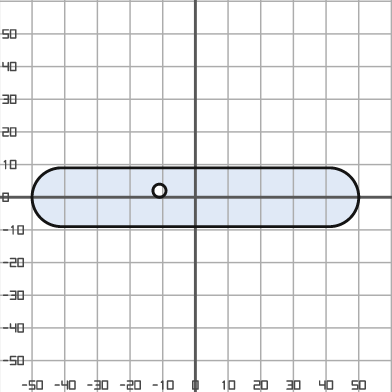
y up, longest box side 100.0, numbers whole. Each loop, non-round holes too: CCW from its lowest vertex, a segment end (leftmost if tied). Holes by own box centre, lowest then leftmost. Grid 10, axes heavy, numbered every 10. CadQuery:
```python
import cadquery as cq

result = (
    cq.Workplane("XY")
    .moveTo(-41.0, -9.0)
    .lineTo(41.0, -9.0)
    .threePointArc((50.0, 0.0), (41.0, 9.0))
    .lineTo(-41.0, 9.0)
    .threePointArc((-50.0, 0.0), (-41.0, -9.0))
    .close()
    .moveTo(-11.0, 2.0)
    .circle(2.0)
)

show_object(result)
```